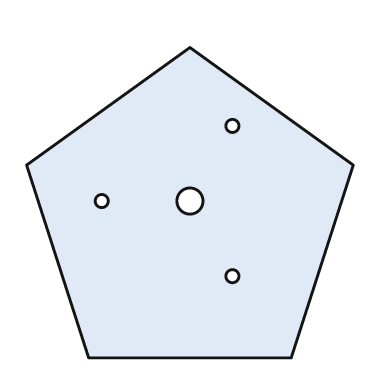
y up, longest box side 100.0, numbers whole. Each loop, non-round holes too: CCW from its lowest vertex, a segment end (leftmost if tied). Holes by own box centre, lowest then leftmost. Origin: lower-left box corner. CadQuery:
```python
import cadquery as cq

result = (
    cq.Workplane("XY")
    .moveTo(19.0, 0.0)
    .lineTo(81.0, 0.0)
    .lineTo(100.0, 59.0)
    .lineTo(50.0, 95.0)
    .lineTo(0.0, 59.0)
    .close()
    .moveTo(63.0, 25.0)
    .circle(2.0)
    .moveTo(23.0, 48.0)
    .circle(2.0)
    .moveTo(50.0, 48.0)
    .circle(4.0)
    .moveTo(63.0, 71.0)
    .circle(2.0)
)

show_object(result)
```